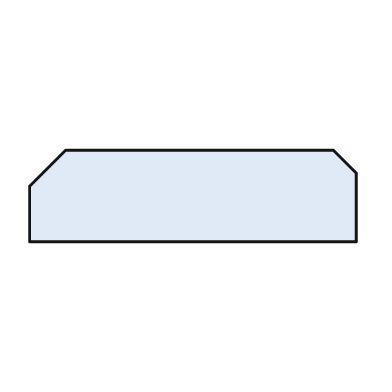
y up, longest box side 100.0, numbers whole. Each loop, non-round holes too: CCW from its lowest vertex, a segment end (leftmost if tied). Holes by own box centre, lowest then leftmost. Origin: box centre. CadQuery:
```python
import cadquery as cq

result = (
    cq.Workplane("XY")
    .moveTo(-50.0, -14.0)
    .lineTo(50.0, -14.0)
    .lineTo(50.0, 7.0)
    .lineTo(43.0, 14.0)
    .lineTo(-39.0, 14.0)
    .lineTo(-50.0, 3.0)
    .close()
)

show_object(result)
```